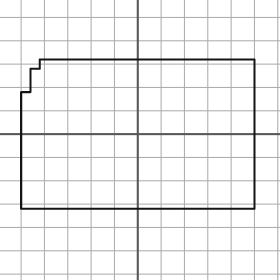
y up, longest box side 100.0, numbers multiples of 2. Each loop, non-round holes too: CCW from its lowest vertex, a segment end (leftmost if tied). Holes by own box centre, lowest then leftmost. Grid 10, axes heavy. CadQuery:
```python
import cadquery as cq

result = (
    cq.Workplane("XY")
    .moveTo(-50.0, -32.0)
    .lineTo(50.0, -32.0)
    .lineTo(50.0, 32.0)
    .lineTo(-42.0, 32.0)
    .lineTo(-42.0, 28.0)
    .lineTo(-46.0, 28.0)
    .lineTo(-46.0, 18.0)
    .lineTo(-50.0, 18.0)
    .close()
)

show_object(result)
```